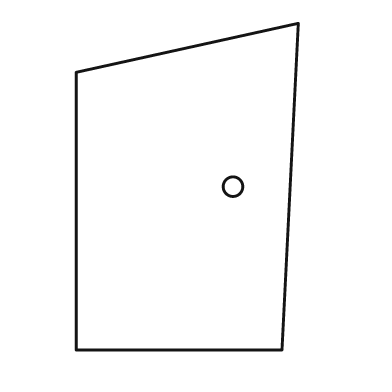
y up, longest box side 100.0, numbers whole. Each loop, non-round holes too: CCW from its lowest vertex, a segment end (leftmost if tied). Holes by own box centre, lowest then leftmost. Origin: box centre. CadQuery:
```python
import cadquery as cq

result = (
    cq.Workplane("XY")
    .moveTo(-34.0, -50.0)
    .lineTo(29.0, -50.0)
    .lineTo(34.0, 50.0)
    .lineTo(-34.0, 35.0)
    .close()
    .moveTo(14.0, 0.0)
    .circle(3.0)
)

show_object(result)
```